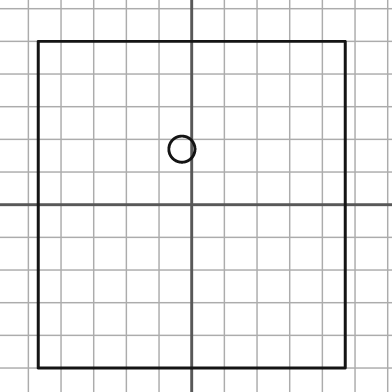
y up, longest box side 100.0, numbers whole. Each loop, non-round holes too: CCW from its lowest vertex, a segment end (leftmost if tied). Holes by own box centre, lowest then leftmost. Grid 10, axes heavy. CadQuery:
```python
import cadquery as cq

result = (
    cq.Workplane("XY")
    .moveTo(-47.0, -50.0)
    .lineTo(47.0, -50.0)
    .lineTo(47.0, 50.0)
    .lineTo(-47.0, 50.0)
    .close()
    .moveTo(-3.0, 17.0)
    .circle(4.0)
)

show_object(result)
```